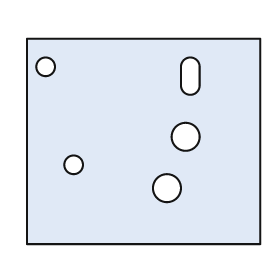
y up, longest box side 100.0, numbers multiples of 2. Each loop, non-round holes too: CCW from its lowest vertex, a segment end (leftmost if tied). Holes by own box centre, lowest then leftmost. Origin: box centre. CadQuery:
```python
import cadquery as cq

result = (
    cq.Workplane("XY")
    .moveTo(-50.0, -44.0)
    .lineTo(50.0, -44.0)
    .lineTo(50.0, 44.0)
    .lineTo(-50.0, 44.0)
    .close()
    .moveTo(10.0, -20.0)
    .circle(6.0)
    .moveTo(-30.0, -10.0)
    .circle(4.0)
    .moveTo(18.0, 2.0)
    .circle(6.0)
    .moveTo(16.0, 24.0)
    .threePointArc((20.0, 20.0), (24.0, 24.0))
    .lineTo(24.0, 32.0)
    .threePointArc((20.0, 36.0), (16.0, 32.0))
    .close()
    .moveTo(-42.0, 32.0)
    .circle(4.0)
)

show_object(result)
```